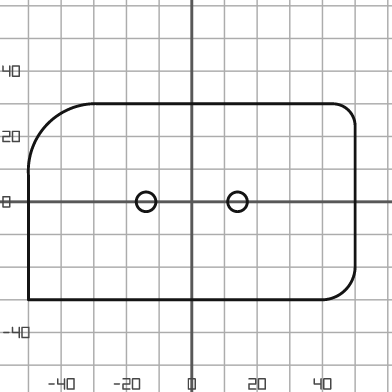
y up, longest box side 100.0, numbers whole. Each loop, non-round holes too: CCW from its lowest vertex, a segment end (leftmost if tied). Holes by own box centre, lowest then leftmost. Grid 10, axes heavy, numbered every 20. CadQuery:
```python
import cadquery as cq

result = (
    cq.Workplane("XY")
    .moveTo(-50.0, -30.0)
    .lineTo(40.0, -30.0)
    .threePointArc((47.0, -27.0), (50.0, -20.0))
    .lineTo(50.0, 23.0)
    .threePointArc((48.0, 28.0), (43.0, 30.0))
    .lineTo(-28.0, 30.0)
    .threePointArc((-44.0, 24.0), (-50.0, 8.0))
    .close()
    .moveTo(-14.0, 0.0)
    .circle(3.0)
    .moveTo(14.0, 0.0)
    .circle(3.0)
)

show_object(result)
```